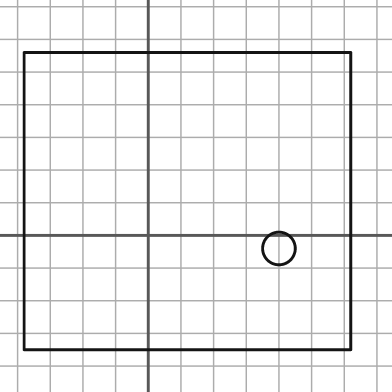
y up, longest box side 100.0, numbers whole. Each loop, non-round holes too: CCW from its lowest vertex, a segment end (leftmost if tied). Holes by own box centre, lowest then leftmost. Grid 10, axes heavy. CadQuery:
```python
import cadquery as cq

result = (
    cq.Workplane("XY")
    .moveTo(-38.0, -35.0)
    .lineTo(62.0, -35.0)
    .lineTo(62.0, 56.0)
    .lineTo(-38.0, 56.0)
    .close()
    .moveTo(40.0, -4.0)
    .circle(5.0)
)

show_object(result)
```